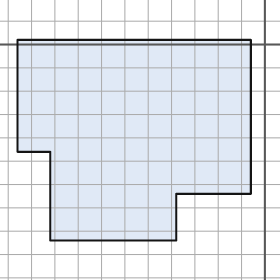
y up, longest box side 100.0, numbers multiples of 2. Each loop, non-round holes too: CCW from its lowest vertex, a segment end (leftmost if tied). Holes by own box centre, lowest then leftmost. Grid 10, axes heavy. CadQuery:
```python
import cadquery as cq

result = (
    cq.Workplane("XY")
    .moveTo(-92.0, -84.0)
    .lineTo(-38.0, -84.0)
    .lineTo(-38.0, -64.0)
    .lineTo(-6.0, -64.0)
    .lineTo(-6.0, 2.0)
    .lineTo(-106.0, 2.0)
    .lineTo(-106.0, -46.0)
    .lineTo(-92.0, -46.0)
    .close()
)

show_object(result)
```